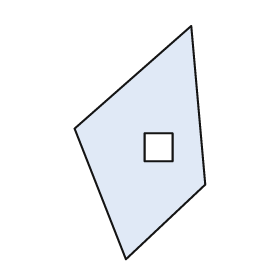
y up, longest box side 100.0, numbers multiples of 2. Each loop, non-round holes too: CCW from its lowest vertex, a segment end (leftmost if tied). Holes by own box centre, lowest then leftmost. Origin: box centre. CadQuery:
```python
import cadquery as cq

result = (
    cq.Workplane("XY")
    .moveTo(-6.0, -50.0)
    .lineTo(28.0, -18.0)
    .lineTo(22.0, 50.0)
    .lineTo(-28.0, 6.0)
    .close()
    .moveTo(2.0, -8.0)
    .lineTo(14.0, -8.0)
    .lineTo(14.0, 4.0)
    .lineTo(2.0, 4.0)
    .close()
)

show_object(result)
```